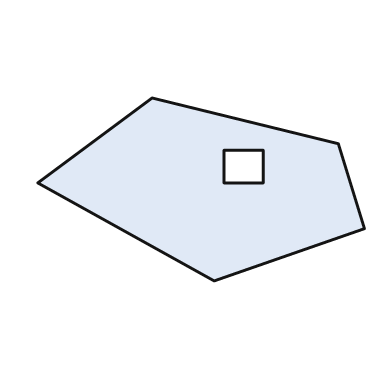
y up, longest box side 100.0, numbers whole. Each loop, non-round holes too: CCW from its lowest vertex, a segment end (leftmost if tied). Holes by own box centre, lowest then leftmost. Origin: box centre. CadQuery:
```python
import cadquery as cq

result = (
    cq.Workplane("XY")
    .moveTo(4.0, -28.0)
    .lineTo(50.0, -12.0)
    .lineTo(42.0, 14.0)
    .lineTo(-15.0, 28.0)
    .lineTo(-50.0, 2.0)
    .close()
    .moveTo(7.0, 2.0)
    .lineTo(19.0, 2.0)
    .lineTo(19.0, 12.0)
    .lineTo(7.0, 12.0)
    .close()
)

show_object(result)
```